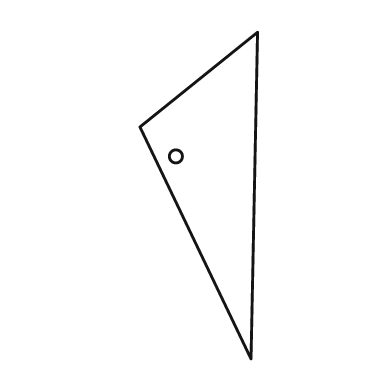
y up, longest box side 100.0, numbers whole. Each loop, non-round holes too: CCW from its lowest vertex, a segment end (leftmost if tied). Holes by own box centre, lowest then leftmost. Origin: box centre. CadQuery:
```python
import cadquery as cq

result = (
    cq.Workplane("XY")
    .moveTo(16.0, -50.0)
    .lineTo(18.0, 50.0)
    .lineTo(-18.0, 21.0)
    .close()
    .moveTo(-7.0, 12.0)
    .circle(2.0)
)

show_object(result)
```